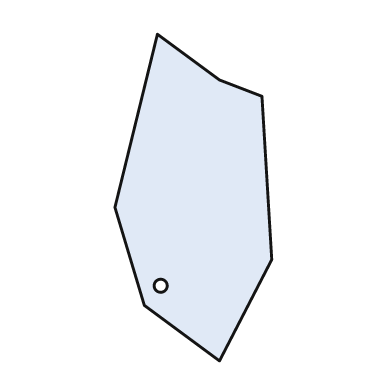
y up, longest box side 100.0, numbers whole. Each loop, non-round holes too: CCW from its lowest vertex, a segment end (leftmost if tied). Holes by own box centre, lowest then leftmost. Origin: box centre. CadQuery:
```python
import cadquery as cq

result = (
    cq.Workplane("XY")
    .moveTo(8.0, -50.0)
    .lineTo(24.0, -19.0)
    .lineTo(21.0, 31.0)
    .lineTo(8.0, 36.0)
    .lineTo(-11.0, 50.0)
    .lineTo(-24.0, -3.0)
    .lineTo(-15.0, -33.0)
    .close()
    .moveTo(-10.0, -27.0)
    .circle(2.0)
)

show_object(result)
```